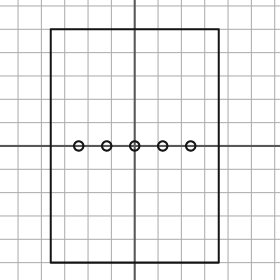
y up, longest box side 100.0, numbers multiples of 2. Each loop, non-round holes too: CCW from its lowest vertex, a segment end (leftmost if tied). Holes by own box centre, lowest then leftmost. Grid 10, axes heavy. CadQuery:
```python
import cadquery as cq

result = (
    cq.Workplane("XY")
    .moveTo(-36.0, -50.0)
    .lineTo(36.0, -50.0)
    .lineTo(36.0, 50.0)
    .lineTo(-36.0, 50.0)
    .close()
    .moveTo(-24.0, 0.0)
    .circle(2.0)
    .moveTo(-12.0, 0.0)
    .circle(2.0)
    .moveTo(0.0, 0.0)
    .circle(2.0)
    .moveTo(12.0, 0.0)
    .circle(2.0)
    .moveTo(24.0, 0.0)
    .circle(2.0)
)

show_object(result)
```